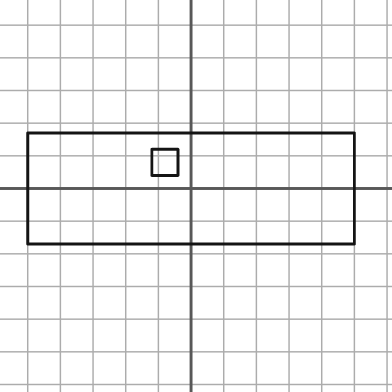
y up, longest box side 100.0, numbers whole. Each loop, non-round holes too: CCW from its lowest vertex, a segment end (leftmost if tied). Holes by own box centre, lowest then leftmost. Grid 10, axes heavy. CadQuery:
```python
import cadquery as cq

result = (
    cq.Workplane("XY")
    .moveTo(-50.0, -17.0)
    .lineTo(50.0, -17.0)
    .lineTo(50.0, 17.0)
    .lineTo(-50.0, 17.0)
    .close()
    .moveTo(-12.0, 4.0)
    .lineTo(-4.0, 4.0)
    .lineTo(-4.0, 12.0)
    .lineTo(-12.0, 12.0)
    .close()
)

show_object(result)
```